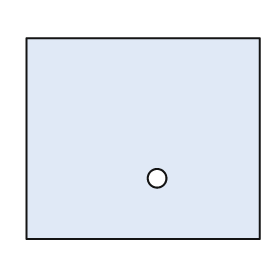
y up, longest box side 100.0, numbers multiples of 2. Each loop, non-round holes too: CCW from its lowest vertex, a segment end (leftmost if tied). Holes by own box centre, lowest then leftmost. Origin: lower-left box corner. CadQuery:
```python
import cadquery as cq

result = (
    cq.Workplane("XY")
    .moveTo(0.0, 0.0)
    .lineTo(100.0, 0.0)
    .lineTo(100.0, 86.0)
    .lineTo(0.0, 86.0)
    .close()
    .moveTo(56.0, 26.0)
    .circle(4.0)
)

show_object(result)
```